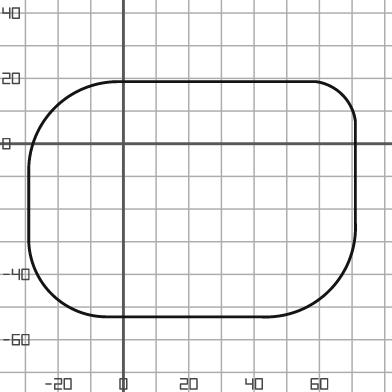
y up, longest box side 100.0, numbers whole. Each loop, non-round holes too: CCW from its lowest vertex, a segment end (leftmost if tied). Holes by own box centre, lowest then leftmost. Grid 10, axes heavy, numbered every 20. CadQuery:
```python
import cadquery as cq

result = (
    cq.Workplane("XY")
    .moveTo(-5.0, -53.0)
    .lineTo(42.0, -53.0)
    .threePointArc((63.0, -45.0), (71.0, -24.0))
    .lineTo(71.0, 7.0)
    .threePointArc((67.0, 15.0), (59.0, 19.0))
    .lineTo(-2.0, 19.0)
    .threePointArc((-21.0, 11.0), (-29.0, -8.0))
    .lineTo(-29.0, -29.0)
    .threePointArc((-22.0, -46.0), (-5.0, -53.0))
    .close()
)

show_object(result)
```